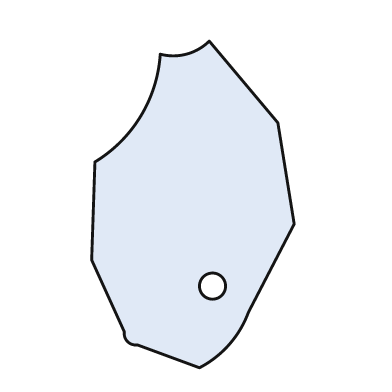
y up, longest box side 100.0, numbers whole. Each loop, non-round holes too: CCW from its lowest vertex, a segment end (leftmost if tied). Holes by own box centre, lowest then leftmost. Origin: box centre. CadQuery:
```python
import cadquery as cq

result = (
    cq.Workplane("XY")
    .moveTo(2.0, -50.0)
    .threePointArc((11.0, -43.0), (17.0, -33.0))
    .lineTo(31.0, -6.0)
    .lineTo(26.0, 25.0)
    .lineTo(5.0, 50.0)
    .threePointArc((-2.0, 46.0), (-10.0, 46.0))
    .threePointArc((-16.0, 27.0), (-30.0, 13.0))
    .lineTo(-31.0, -17.0)
    .lineTo(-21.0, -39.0)
    .threePointArc((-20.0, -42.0), (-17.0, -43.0))
    .close()
    .moveTo(6.0, -25.0)
    .circle(4.0)
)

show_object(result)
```